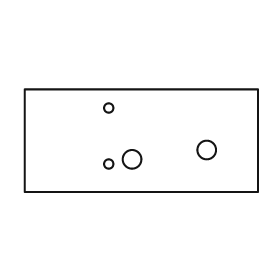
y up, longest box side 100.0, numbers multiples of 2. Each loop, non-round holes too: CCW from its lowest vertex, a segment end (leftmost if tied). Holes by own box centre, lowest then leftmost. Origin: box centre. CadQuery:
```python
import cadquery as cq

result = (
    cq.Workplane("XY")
    .moveTo(-50.0, -22.0)
    .lineTo(50.0, -22.0)
    .lineTo(50.0, 22.0)
    .lineTo(-50.0, 22.0)
    .close()
    .moveTo(-14.0, -10.0)
    .circle(2.0)
    .moveTo(-4.0, -8.0)
    .circle(4.0)
    .moveTo(28.0, -4.0)
    .circle(4.0)
    .moveTo(-14.0, 14.0)
    .circle(2.0)
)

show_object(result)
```